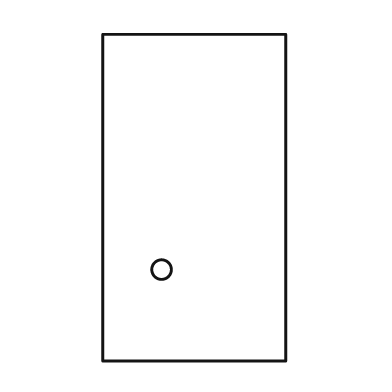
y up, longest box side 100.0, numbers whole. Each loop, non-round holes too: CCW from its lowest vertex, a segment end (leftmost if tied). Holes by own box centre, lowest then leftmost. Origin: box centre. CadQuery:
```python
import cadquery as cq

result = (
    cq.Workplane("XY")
    .moveTo(-28.0, -50.0)
    .lineTo(28.0, -50.0)
    .lineTo(28.0, 50.0)
    .lineTo(-28.0, 50.0)
    .close()
    .moveTo(-10.0, -22.0)
    .circle(3.0)
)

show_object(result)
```